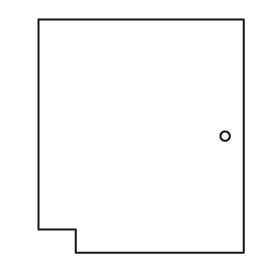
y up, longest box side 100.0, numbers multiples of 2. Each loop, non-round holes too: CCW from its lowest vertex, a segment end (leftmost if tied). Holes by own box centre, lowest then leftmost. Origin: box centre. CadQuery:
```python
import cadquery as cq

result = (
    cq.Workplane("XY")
    .moveTo(-28.0, -50.0)
    .lineTo(44.0, -50.0)
    .lineTo(44.0, 50.0)
    .lineTo(-44.0, 50.0)
    .lineTo(-44.0, -40.0)
    .lineTo(-28.0, -40.0)
    .close()
    .moveTo(36.0, 0.0)
    .circle(2.0)
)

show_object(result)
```